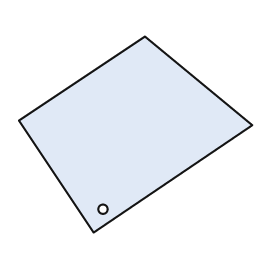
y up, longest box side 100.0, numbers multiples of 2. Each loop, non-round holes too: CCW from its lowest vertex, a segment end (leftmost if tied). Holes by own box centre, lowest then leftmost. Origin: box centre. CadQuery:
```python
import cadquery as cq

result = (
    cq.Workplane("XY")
    .moveTo(-18.0, -42.0)
    .lineTo(50.0, 4.0)
    .lineTo(4.0, 42.0)
    .lineTo(-50.0, 6.0)
    .close()
    .moveTo(-14.0, -32.0)
    .circle(2.0)
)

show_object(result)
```